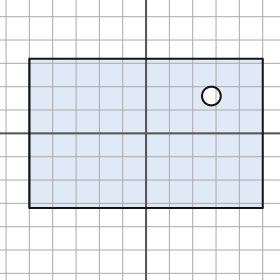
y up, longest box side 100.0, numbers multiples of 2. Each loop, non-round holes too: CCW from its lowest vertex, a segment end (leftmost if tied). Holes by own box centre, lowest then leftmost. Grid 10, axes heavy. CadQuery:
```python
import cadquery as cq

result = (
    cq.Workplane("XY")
    .moveTo(-50.0, -32.0)
    .lineTo(50.0, -32.0)
    .lineTo(50.0, 32.0)
    .lineTo(-50.0, 32.0)
    .close()
    .moveTo(28.0, 16.0)
    .circle(4.0)
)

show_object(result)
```